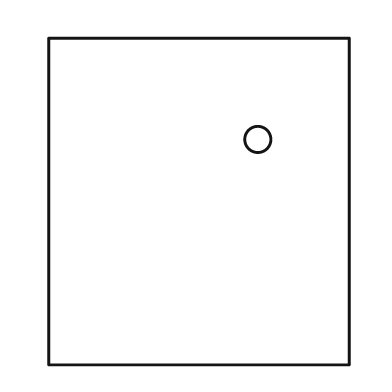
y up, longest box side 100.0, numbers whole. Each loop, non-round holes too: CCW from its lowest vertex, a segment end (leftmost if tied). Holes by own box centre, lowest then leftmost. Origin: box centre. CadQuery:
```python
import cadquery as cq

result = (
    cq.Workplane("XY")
    .moveTo(-46.0, -50.0)
    .lineTo(46.0, -50.0)
    .lineTo(46.0, 50.0)
    .lineTo(-46.0, 50.0)
    .close()
    .moveTo(18.0, 19.0)
    .circle(4.0)
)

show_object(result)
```